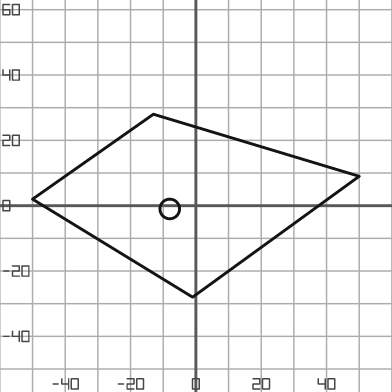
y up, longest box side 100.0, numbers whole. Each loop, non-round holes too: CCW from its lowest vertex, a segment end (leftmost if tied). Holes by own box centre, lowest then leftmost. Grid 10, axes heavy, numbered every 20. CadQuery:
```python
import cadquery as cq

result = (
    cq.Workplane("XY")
    .moveTo(-1.0, -28.0)
    .lineTo(50.0, 9.0)
    .lineTo(-13.0, 28.0)
    .lineTo(-50.0, 2.0)
    .close()
    .moveTo(-8.0, -1.0)
    .circle(3.0)
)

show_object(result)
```